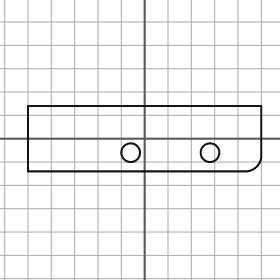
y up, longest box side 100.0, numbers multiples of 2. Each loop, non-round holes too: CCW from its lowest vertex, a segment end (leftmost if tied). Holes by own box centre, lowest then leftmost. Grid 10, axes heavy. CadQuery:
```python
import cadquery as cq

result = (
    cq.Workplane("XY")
    .moveTo(-50.0, -14.0)
    .lineTo(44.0, -14.0)
    .threePointArc((48.0, -12.0), (50.0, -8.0))
    .lineTo(50.0, 14.0)
    .lineTo(-50.0, 14.0)
    .close()
    .moveTo(-6.0, -6.0)
    .circle(4.0)
    .moveTo(28.0, -6.0)
    .circle(4.0)
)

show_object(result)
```